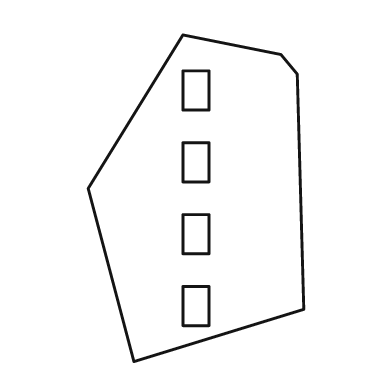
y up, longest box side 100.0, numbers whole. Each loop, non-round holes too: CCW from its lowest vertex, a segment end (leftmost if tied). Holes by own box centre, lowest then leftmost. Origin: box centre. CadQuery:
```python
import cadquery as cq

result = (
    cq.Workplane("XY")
    .moveTo(-19.0, -50.0)
    .lineTo(33.0, -34.0)
    .lineTo(31.0, 38.0)
    .lineTo(26.0, 44.0)
    .lineTo(-4.0, 50.0)
    .lineTo(-33.0, 3.0)
    .close()
    .moveTo(-4.0, -39.0)
    .lineTo(4.0, -39.0)
    .lineTo(4.0, -27.0)
    .lineTo(-4.0, -27.0)
    .close()
    .moveTo(-4.0, -17.0)
    .lineTo(4.0, -17.0)
    .lineTo(4.0, -5.0)
    .lineTo(-4.0, -5.0)
    .close()
    .moveTo(-4.0, 5.0)
    .lineTo(4.0, 5.0)
    .lineTo(4.0, 17.0)
    .lineTo(-4.0, 17.0)
    .close()
    .moveTo(-4.0, 27.0)
    .lineTo(4.0, 27.0)
    .lineTo(4.0, 39.0)
    .lineTo(-4.0, 39.0)
    .close()
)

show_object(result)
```